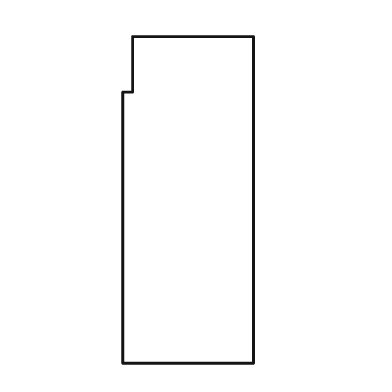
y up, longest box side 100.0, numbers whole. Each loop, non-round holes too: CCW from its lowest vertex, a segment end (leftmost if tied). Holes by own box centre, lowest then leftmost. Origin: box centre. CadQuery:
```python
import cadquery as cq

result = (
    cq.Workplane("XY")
    .moveTo(-20.0, -50.0)
    .lineTo(20.0, -50.0)
    .lineTo(20.0, 50.0)
    .lineTo(-17.0, 50.0)
    .lineTo(-17.0, 33.0)
    .lineTo(-20.0, 33.0)
    .close()
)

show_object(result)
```